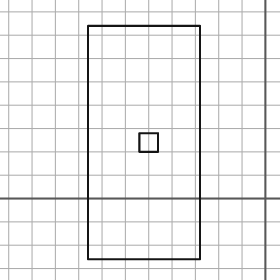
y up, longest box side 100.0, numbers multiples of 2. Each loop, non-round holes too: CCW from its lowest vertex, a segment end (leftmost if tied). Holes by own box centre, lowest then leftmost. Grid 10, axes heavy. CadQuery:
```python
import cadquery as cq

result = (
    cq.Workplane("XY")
    .moveTo(-76.0, -26.0)
    .lineTo(-28.0, -26.0)
    .lineTo(-28.0, 74.0)
    .lineTo(-76.0, 74.0)
    .close()
    .moveTo(-54.0, 20.0)
    .lineTo(-46.0, 20.0)
    .lineTo(-46.0, 28.0)
    .lineTo(-54.0, 28.0)
    .close()
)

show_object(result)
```